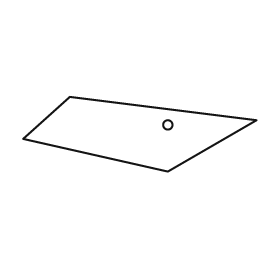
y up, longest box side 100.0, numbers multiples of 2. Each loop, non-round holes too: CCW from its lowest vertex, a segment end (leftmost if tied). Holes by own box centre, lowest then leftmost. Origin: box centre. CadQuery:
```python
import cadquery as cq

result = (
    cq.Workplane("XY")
    .moveTo(12.0, -16.0)
    .lineTo(50.0, 6.0)
    .lineTo(-30.0, 16.0)
    .lineTo(-50.0, -2.0)
    .close()
    .moveTo(12.0, 4.0)
    .circle(2.0)
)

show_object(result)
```